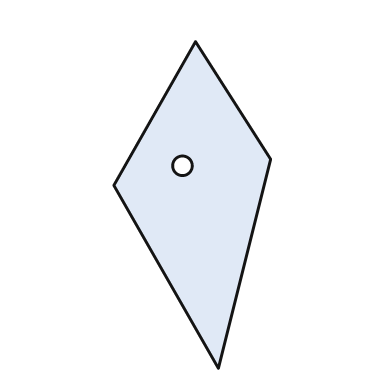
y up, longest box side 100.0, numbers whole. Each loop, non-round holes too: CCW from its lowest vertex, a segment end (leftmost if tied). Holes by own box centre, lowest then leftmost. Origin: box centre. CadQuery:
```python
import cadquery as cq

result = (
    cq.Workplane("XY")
    .moveTo(8.0, -50.0)
    .lineTo(24.0, 14.0)
    .lineTo(1.0, 50.0)
    .lineTo(-24.0, 6.0)
    .close()
    .moveTo(-3.0, 12.0)
    .circle(3.0)
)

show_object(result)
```